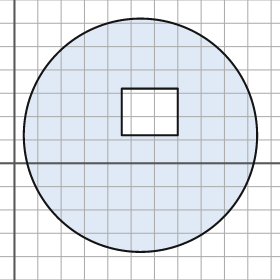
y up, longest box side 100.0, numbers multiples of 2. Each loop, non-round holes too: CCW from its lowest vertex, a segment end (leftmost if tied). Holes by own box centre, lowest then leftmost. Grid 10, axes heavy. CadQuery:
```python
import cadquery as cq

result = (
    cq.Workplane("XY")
    .moveTo(54.0, 12.0)
    .circle(50.0)
    .moveTo(46.0, 12.0)
    .lineTo(70.0, 12.0)
    .lineTo(70.0, 32.0)
    .lineTo(46.0, 32.0)
    .close()
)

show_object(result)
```